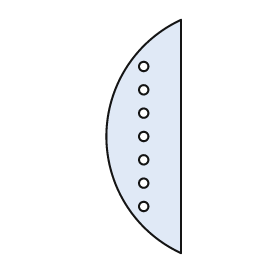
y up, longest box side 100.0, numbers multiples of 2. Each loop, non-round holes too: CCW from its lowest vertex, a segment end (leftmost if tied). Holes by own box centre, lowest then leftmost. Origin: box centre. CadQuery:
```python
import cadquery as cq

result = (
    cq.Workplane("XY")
    .moveTo(16.0, -50.0)
    .lineTo(16.0, 50.0)
    .threePointArc((-16.0, 0.0), (16.0, -50.0))
    .close()
    .moveTo(0.0, -30.0)
    .circle(2.0)
    .moveTo(0.0, -20.0)
    .circle(2.0)
    .moveTo(0.0, -10.0)
    .circle(2.0)
    .moveTo(0.0, 0.0)
    .circle(2.0)
    .moveTo(0.0, 10.0)
    .circle(2.0)
    .moveTo(0.0, 20.0)
    .circle(2.0)
    .moveTo(0.0, 30.0)
    .circle(2.0)
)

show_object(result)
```